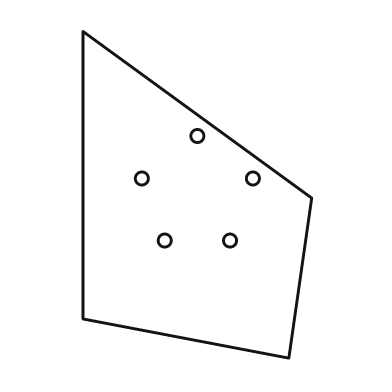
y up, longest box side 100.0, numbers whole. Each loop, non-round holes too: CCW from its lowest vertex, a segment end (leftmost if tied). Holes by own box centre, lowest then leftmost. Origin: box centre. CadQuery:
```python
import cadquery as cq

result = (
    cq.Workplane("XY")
    .moveTo(28.0, -50.0)
    .lineTo(35.0, -1.0)
    .lineTo(-35.0, 50.0)
    .lineTo(-35.0, -38.0)
    .close()
    .moveTo(-10.0, -14.0)
    .circle(2.0)
    .moveTo(10.0, -14.0)
    .circle(2.0)
    .moveTo(-17.0, 5.0)
    .circle(2.0)
    .moveTo(17.0, 5.0)
    .circle(2.0)
    .moveTo(0.0, 18.0)
    .circle(2.0)
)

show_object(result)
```